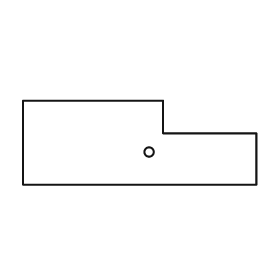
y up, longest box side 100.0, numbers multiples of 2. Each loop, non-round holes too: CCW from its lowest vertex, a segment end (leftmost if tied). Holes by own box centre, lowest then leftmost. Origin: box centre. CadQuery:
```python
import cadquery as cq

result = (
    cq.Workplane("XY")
    .moveTo(-50.0, -18.0)
    .lineTo(50.0, -18.0)
    .lineTo(50.0, 4.0)
    .lineTo(10.0, 4.0)
    .lineTo(10.0, 18.0)
    .lineTo(-50.0, 18.0)
    .close()
    .moveTo(4.0, -4.0)
    .circle(2.0)
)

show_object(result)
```